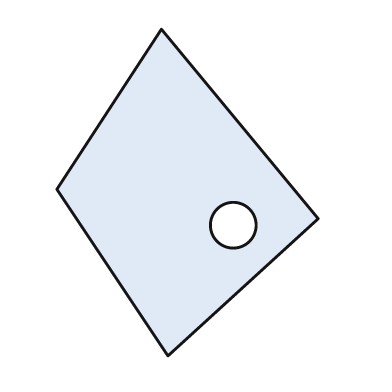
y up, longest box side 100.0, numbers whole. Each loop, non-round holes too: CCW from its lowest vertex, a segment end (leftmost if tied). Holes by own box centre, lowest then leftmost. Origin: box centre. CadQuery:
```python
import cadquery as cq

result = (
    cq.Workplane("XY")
    .moveTo(-6.0, -50.0)
    .lineTo(40.0, -8.0)
    .lineTo(-8.0, 50.0)
    .lineTo(-40.0, 1.0)
    .close()
    .moveTo(14.0, -10.0)
    .circle(7.0)
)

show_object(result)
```